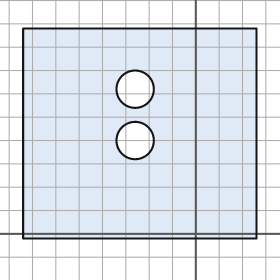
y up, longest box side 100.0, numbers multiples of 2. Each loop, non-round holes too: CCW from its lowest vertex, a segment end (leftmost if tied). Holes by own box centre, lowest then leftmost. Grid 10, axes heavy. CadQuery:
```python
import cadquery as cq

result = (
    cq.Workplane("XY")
    .moveTo(-74.0, -2.0)
    .lineTo(26.0, -2.0)
    .lineTo(26.0, 88.0)
    .lineTo(-74.0, 88.0)
    .close()
    .moveTo(-26.0, 40.0)
    .circle(8.0)
    .moveTo(-26.0, 62.0)
    .circle(8.0)
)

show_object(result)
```